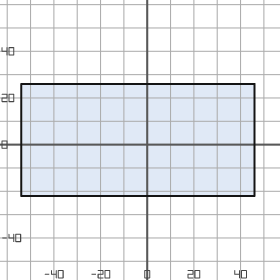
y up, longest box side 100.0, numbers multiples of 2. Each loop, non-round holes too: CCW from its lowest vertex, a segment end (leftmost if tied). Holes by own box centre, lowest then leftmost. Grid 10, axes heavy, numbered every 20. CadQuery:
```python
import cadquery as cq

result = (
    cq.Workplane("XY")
    .moveTo(-54.0, -22.0)
    .lineTo(46.0, -22.0)
    .lineTo(46.0, 26.0)
    .lineTo(-54.0, 26.0)
    .close()
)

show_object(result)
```